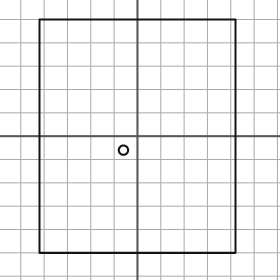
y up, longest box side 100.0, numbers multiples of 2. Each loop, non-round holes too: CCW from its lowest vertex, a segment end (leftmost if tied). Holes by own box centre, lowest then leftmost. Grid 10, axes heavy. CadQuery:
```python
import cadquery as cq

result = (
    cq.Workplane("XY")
    .moveTo(-42.0, -50.0)
    .lineTo(42.0, -50.0)
    .lineTo(42.0, 50.0)
    .lineTo(-42.0, 50.0)
    .close()
    .moveTo(-6.0, -6.0)
    .circle(2.0)
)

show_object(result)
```